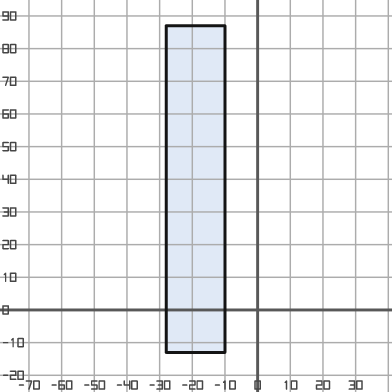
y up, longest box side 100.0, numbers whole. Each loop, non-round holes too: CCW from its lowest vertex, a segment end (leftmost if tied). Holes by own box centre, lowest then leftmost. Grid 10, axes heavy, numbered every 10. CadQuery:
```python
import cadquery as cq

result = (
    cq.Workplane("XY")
    .moveTo(-28.0, -13.0)
    .lineTo(-10.0, -13.0)
    .lineTo(-10.0, 87.0)
    .lineTo(-28.0, 87.0)
    .close()
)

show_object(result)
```